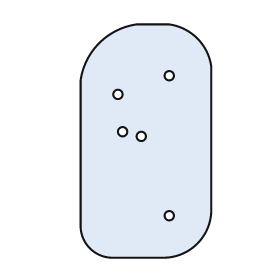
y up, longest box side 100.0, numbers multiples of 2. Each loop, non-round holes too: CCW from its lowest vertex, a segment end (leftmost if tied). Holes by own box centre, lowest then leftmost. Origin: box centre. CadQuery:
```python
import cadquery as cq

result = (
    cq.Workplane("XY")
    .moveTo(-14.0, -50.0)
    .lineTo(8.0, -50.0)
    .threePointArc((22.0, -44.0), (28.0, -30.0))
    .lineTo(28.0, 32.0)
    .threePointArc((22.0, 44.0), (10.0, 50.0))
    .lineTo(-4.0, 50.0)
    .threePointArc((-20.0, 42.0), (-28.0, 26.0))
    .lineTo(-28.0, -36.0)
    .threePointArc((-24.0, -46.0), (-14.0, -50.0))
    .close()
    .moveTo(10.0, -32.0)
    .circle(2.0)
    .moveTo(-2.0, 2.0)
    .circle(2.0)
    .moveTo(-10.0, 4.0)
    .circle(2.0)
    .moveTo(-12.0, 20.0)
    .circle(2.0)
    .moveTo(10.0, 28.0)
    .circle(2.0)
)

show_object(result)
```